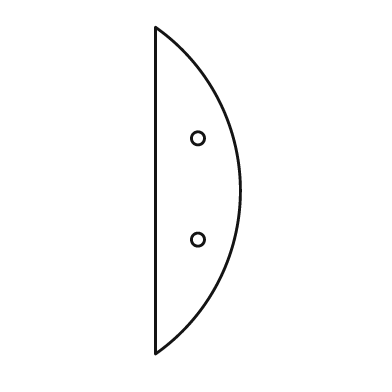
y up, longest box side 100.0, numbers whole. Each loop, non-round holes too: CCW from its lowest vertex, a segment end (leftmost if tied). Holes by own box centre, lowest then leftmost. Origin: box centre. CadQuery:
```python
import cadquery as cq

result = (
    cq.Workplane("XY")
    .moveTo(-13.0, -50.0)
    .threePointArc((13.0, 0.0), (-13.0, 50.0))
    .close()
    .moveTo(0.0, -15.0)
    .circle(2.0)
    .moveTo(0.0, 16.0)
    .circle(2.0)
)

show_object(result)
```